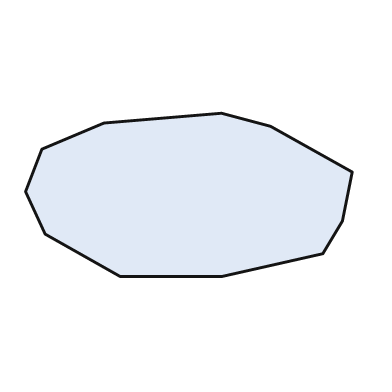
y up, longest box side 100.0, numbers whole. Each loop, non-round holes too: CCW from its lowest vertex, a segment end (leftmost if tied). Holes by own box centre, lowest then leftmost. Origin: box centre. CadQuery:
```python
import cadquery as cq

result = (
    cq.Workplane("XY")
    .moveTo(-21.0, -25.0)
    .lineTo(10.0, -25.0)
    .lineTo(41.0, -18.0)
    .lineTo(47.0, -8.0)
    .lineTo(50.0, 7.0)
    .lineTo(25.0, 21.0)
    .lineTo(10.0, 25.0)
    .lineTo(-26.0, 22.0)
    .lineTo(-45.0, 14.0)
    .lineTo(-50.0, 1.0)
    .lineTo(-44.0, -12.0)
    .close()
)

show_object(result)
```